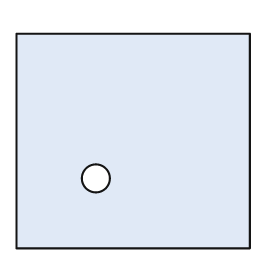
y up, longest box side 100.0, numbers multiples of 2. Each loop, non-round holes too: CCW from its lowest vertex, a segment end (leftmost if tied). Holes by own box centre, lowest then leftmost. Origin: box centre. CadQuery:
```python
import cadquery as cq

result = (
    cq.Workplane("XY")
    .moveTo(-50.0, -46.0)
    .lineTo(50.0, -46.0)
    .lineTo(50.0, 46.0)
    .lineTo(-50.0, 46.0)
    .close()
    .moveTo(-16.0, -16.0)
    .circle(6.0)
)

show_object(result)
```